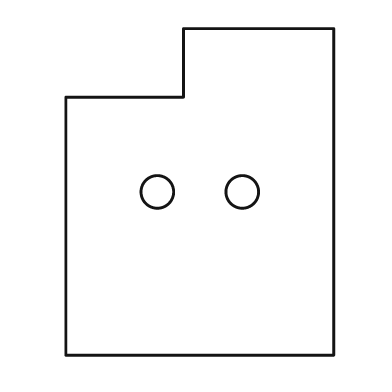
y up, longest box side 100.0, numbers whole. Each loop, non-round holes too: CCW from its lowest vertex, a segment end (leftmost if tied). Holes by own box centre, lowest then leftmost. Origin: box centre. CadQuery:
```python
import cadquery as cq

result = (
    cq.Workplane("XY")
    .moveTo(-41.0, -50.0)
    .lineTo(41.0, -50.0)
    .lineTo(41.0, 50.0)
    .lineTo(-5.0, 50.0)
    .lineTo(-5.0, 29.0)
    .lineTo(-41.0, 29.0)
    .close()
    .moveTo(-13.0, 0.0)
    .circle(5.0)
    .moveTo(13.0, 0.0)
    .circle(5.0)
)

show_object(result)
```